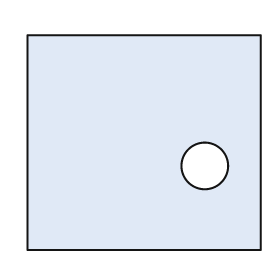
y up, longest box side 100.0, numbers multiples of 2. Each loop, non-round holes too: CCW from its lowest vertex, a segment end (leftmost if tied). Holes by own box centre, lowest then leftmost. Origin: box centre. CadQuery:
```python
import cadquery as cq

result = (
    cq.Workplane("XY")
    .moveTo(-50.0, -46.0)
    .lineTo(50.0, -46.0)
    .lineTo(50.0, 46.0)
    .lineTo(-50.0, 46.0)
    .close()
    .moveTo(26.0, -10.0)
    .circle(10.0)
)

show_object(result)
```